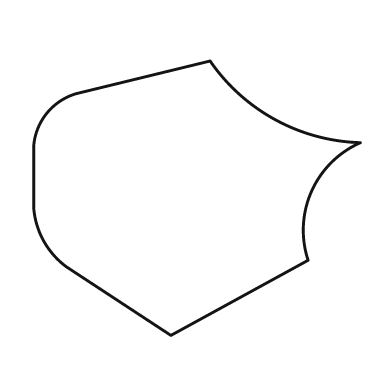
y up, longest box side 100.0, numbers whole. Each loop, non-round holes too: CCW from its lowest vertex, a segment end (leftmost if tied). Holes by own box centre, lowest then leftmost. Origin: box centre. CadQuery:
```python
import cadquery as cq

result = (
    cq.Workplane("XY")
    .moveTo(-8.0, -42.0)
    .lineTo(34.0, -19.0)
    .threePointArc((35.0, 2.0), (50.0, 17.0))
    .threePointArc((24.0, 24.0), (4.0, 42.0))
    .lineTo(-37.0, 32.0)
    .threePointArc((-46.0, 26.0), (-50.0, 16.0))
    .lineTo(-50.0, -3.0)
    .threePointArc((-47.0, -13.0), (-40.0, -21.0))
    .close()
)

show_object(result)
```